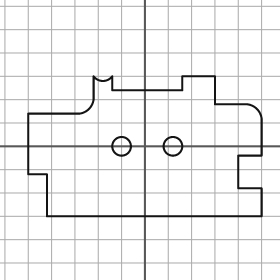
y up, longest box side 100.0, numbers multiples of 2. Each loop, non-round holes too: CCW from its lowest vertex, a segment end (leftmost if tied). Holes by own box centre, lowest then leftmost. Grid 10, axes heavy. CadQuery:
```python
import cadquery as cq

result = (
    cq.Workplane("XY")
    .moveTo(-42.0, -30.0)
    .lineTo(50.0, -30.0)
    .lineTo(50.0, -18.0)
    .lineTo(40.0, -18.0)
    .lineTo(40.0, -4.0)
    .lineTo(50.0, -4.0)
    .lineTo(50.0, 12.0)
    .threePointArc((48.0, 16.0), (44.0, 18.0))
    .lineTo(30.0, 18.0)
    .lineTo(30.0, 30.0)
    .lineTo(16.0, 30.0)
    .lineTo(16.0, 24.0)
    .lineTo(-14.0, 24.0)
    .lineTo(-14.0, 30.0)
    .threePointArc((-18.0, 28.0), (-22.0, 30.0))
    .lineTo(-22.0, 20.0)
    .threePointArc((-24.0, 16.0), (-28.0, 14.0))
    .lineTo(-50.0, 14.0)
    .lineTo(-50.0, -12.0)
    .lineTo(-42.0, -12.0)
    .close()
    .moveTo(-10.0, 0.0)
    .circle(4.0)
    .moveTo(12.0, 0.0)
    .circle(4.0)
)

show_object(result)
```